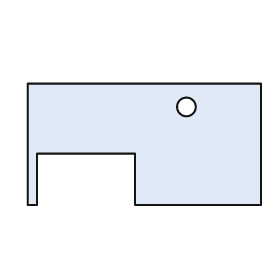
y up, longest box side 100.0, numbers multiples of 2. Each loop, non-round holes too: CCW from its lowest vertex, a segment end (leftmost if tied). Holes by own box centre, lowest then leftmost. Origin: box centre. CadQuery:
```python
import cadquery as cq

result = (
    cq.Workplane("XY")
    .moveTo(-50.0, -26.0)
    .lineTo(-46.0, -26.0)
    .lineTo(-46.0, -4.0)
    .lineTo(-4.0, -4.0)
    .lineTo(-4.0, -26.0)
    .lineTo(50.0, -26.0)
    .lineTo(50.0, 26.0)
    .lineTo(-50.0, 26.0)
    .close()
    .moveTo(18.0, 16.0)
    .circle(4.0)
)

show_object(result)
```